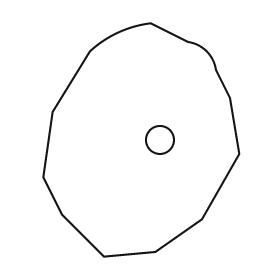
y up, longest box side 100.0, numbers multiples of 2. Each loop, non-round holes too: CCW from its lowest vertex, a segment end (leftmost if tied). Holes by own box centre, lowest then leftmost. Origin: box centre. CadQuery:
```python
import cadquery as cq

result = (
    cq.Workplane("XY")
    .moveTo(-16.0, -50.0)
    .lineTo(6.0, -48.0)
    .lineTo(26.0, -34.0)
    .lineTo(42.0, -6.0)
    .lineTo(38.0, 18.0)
    .lineTo(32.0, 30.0)
    .threePointArc((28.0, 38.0), (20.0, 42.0))
    .lineTo(4.0, 50.0)
    .threePointArc((-10.0, 46.0), (-22.0, 38.0))
    .lineTo(-38.0, 12.0)
    .lineTo(-42.0, -16.0)
    .lineTo(-34.0, -32.0)
    .close()
    .moveTo(8.0, 0.0)
    .circle(6.0)
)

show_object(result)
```